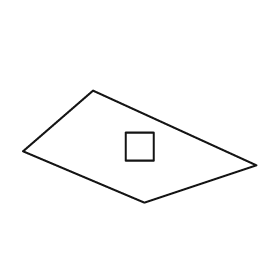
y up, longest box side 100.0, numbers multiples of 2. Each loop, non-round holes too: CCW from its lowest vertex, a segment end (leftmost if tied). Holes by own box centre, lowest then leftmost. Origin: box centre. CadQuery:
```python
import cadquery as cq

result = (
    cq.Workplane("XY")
    .moveTo(2.0, -24.0)
    .lineTo(50.0, -8.0)
    .lineTo(-20.0, 24.0)
    .lineTo(-50.0, -2.0)
    .close()
    .moveTo(-6.0, -6.0)
    .lineTo(6.0, -6.0)
    .lineTo(6.0, 6.0)
    .lineTo(-6.0, 6.0)
    .close()
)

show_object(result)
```